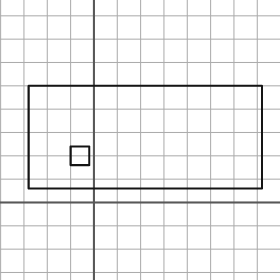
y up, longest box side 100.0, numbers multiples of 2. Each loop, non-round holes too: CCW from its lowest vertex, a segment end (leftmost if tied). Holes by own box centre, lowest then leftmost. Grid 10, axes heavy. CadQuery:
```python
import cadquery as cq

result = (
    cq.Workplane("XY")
    .moveTo(-28.0, 6.0)
    .lineTo(72.0, 6.0)
    .lineTo(72.0, 50.0)
    .lineTo(-28.0, 50.0)
    .close()
    .moveTo(-10.0, 16.0)
    .lineTo(-2.0, 16.0)
    .lineTo(-2.0, 24.0)
    .lineTo(-10.0, 24.0)
    .close()
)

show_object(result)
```